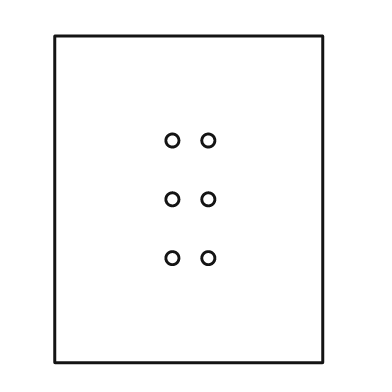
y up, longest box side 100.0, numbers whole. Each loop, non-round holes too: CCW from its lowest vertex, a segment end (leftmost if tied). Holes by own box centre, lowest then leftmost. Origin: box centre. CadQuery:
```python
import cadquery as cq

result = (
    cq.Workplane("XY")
    .moveTo(-41.0, -50.0)
    .lineTo(41.0, -50.0)
    .lineTo(41.0, 50.0)
    .lineTo(-41.0, 50.0)
    .close()
    .moveTo(-5.0, -18.0)
    .circle(2.0)
    .moveTo(6.0, -18.0)
    .circle(2.0)
    .moveTo(-5.0, 0.0)
    .circle(2.0)
    .moveTo(6.0, 0.0)
    .circle(2.0)
    .moveTo(-5.0, 18.0)
    .circle(2.0)
    .moveTo(6.0, 18.0)
    .circle(2.0)
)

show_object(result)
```